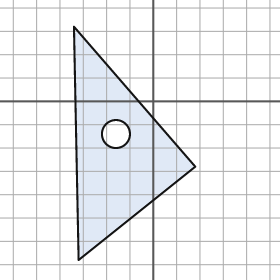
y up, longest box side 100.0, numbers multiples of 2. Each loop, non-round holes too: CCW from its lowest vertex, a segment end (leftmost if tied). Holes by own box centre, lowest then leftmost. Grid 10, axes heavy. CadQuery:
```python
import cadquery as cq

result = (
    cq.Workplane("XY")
    .moveTo(-32.0, -68.0)
    .lineTo(18.0, -28.0)
    .lineTo(-34.0, 32.0)
    .close()
    .moveTo(-16.0, -14.0)
    .circle(6.0)
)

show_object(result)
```